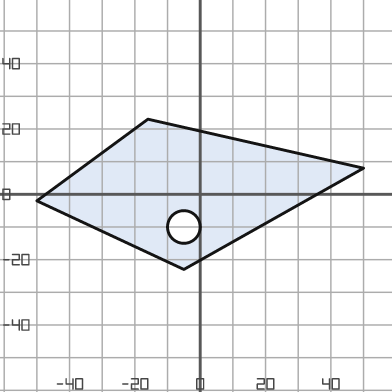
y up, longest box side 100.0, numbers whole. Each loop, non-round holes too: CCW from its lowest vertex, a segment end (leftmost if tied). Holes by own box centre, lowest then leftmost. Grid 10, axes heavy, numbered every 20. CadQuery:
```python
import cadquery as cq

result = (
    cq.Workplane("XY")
    .moveTo(-5.0, -23.0)
    .lineTo(50.0, 8.0)
    .lineTo(-16.0, 23.0)
    .lineTo(-50.0, -2.0)
    .close()
    .moveTo(-5.0, -10.0)
    .circle(5.0)
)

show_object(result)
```